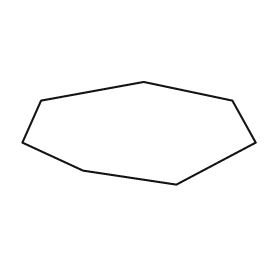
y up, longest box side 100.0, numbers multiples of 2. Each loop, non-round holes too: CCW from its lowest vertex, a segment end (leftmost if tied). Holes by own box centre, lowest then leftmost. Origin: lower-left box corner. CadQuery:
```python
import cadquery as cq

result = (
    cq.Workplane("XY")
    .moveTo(66.0, 0.0)
    .lineTo(100.0, 18.0)
    .lineTo(90.0, 36.0)
    .lineTo(52.0, 44.0)
    .lineTo(8.0, 36.0)
    .lineTo(0.0, 18.0)
    .lineTo(26.0, 6.0)
    .close()
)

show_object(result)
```